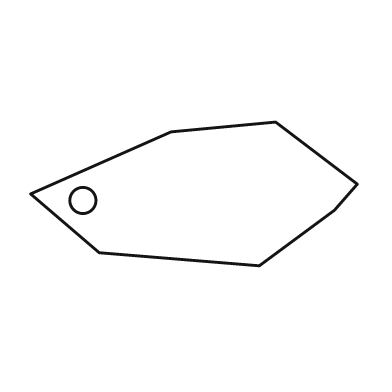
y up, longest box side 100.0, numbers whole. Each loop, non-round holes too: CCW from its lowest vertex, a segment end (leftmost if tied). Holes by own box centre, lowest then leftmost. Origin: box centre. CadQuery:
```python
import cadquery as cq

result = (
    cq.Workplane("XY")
    .moveTo(20.0, -22.0)
    .lineTo(43.0, -5.0)
    .lineTo(50.0, 3.0)
    .lineTo(25.0, 22.0)
    .lineTo(-7.0, 19.0)
    .lineTo(-50.0, 0.0)
    .lineTo(-29.0, -18.0)
    .close()
    .moveTo(-34.0, -2.0)
    .circle(4.0)
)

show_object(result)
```